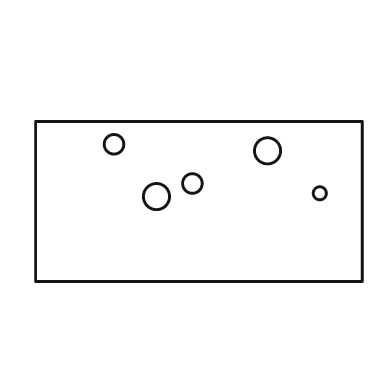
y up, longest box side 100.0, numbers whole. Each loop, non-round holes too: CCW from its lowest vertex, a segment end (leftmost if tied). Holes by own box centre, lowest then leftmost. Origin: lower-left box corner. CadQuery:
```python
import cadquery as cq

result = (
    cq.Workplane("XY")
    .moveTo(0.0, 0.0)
    .lineTo(100.0, 0.0)
    .lineTo(100.0, 49.0)
    .lineTo(0.0, 49.0)
    .close()
    .moveTo(37.0, 26.0)
    .circle(4.0)
    .moveTo(87.0, 27.0)
    .circle(2.0)
    .moveTo(48.0, 30.0)
    .circle(3.0)
    .moveTo(71.0, 40.0)
    .circle(4.0)
    .moveTo(24.0, 42.0)
    .circle(3.0)
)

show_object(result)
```